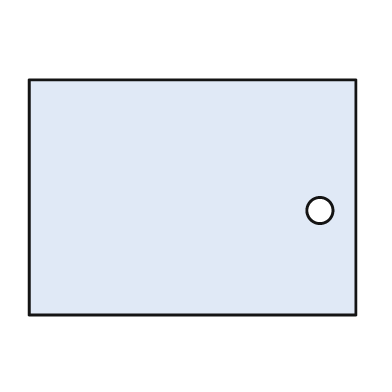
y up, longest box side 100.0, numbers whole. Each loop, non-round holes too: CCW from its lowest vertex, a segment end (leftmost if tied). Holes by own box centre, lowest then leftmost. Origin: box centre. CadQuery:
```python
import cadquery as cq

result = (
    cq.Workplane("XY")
    .moveTo(-50.0, -36.0)
    .lineTo(50.0, -36.0)
    .lineTo(50.0, 36.0)
    .lineTo(-50.0, 36.0)
    .close()
    .moveTo(39.0, -4.0)
    .circle(4.0)
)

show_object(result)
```